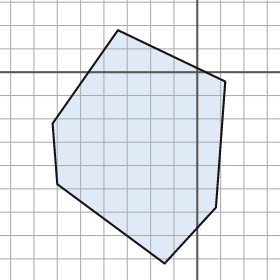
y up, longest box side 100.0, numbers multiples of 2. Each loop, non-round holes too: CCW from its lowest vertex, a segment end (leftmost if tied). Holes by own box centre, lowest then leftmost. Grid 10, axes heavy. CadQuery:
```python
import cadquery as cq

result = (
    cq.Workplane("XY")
    .moveTo(-14.0, -82.0)
    .lineTo(8.0, -58.0)
    .lineTo(12.0, -4.0)
    .lineTo(-34.0, 18.0)
    .lineTo(-62.0, -22.0)
    .lineTo(-60.0, -48.0)
    .close()
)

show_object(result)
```